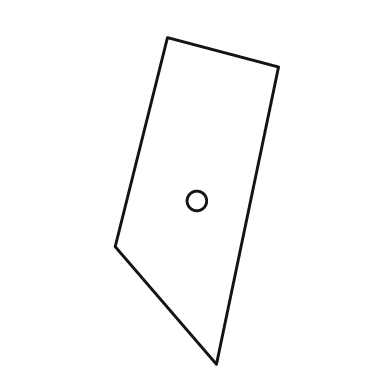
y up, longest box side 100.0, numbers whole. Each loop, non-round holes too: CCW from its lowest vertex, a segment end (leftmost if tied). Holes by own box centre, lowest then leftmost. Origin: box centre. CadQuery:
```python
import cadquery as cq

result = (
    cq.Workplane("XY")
    .moveTo(6.0, -50.0)
    .lineTo(25.0, 41.0)
    .lineTo(-9.0, 50.0)
    .lineTo(-25.0, -14.0)
    .close()
    .moveTo(0.0, 0.0)
    .circle(3.0)
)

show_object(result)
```